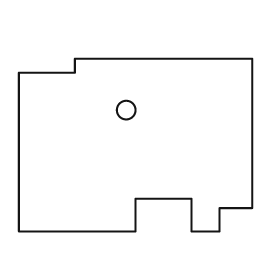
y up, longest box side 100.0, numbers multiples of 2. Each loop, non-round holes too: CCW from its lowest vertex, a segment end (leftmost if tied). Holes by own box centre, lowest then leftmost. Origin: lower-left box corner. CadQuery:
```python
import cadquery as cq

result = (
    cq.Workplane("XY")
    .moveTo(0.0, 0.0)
    .lineTo(50.0, 0.0)
    .lineTo(50.0, 14.0)
    .lineTo(74.0, 14.0)
    .lineTo(74.0, 0.0)
    .lineTo(86.0, 0.0)
    .lineTo(86.0, 10.0)
    .lineTo(100.0, 10.0)
    .lineTo(100.0, 74.0)
    .lineTo(24.0, 74.0)
    .lineTo(24.0, 68.0)
    .lineTo(0.0, 68.0)
    .close()
    .moveTo(46.0, 52.0)
    .circle(4.0)
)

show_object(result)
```